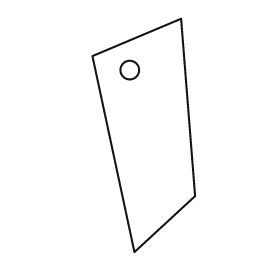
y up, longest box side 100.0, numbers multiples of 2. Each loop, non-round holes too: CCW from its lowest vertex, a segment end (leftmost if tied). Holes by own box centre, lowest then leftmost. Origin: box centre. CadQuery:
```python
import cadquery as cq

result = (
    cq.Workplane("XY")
    .moveTo(-4.0, -50.0)
    .lineTo(22.0, -26.0)
    .lineTo(16.0, 50.0)
    .lineTo(-22.0, 34.0)
    .close()
    .moveTo(-6.0, 28.0)
    .circle(4.0)
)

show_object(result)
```